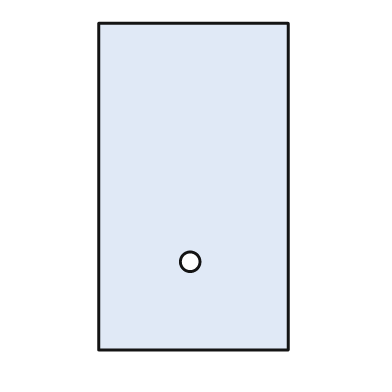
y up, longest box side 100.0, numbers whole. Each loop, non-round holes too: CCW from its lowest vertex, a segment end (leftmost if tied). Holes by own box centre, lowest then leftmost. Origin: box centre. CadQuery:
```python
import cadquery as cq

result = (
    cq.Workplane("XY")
    .moveTo(-29.0, -50.0)
    .lineTo(29.0, -50.0)
    .lineTo(29.0, 50.0)
    .lineTo(-29.0, 50.0)
    .close()
    .moveTo(-1.0, -23.0)
    .circle(3.0)
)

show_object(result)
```